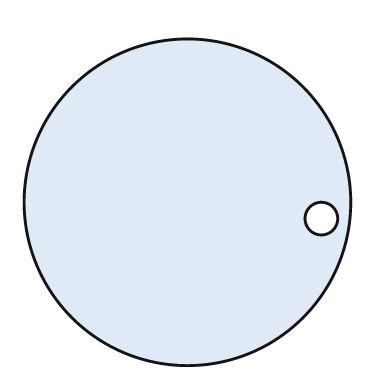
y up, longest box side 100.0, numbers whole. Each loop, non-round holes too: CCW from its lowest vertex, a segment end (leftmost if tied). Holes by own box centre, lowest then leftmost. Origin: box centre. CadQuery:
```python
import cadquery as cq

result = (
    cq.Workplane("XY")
    .moveTo(0.0, 0.0)
    .circle(50.0)
    .moveTo(41.0, -5.0)
    .circle(5.0)
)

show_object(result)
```